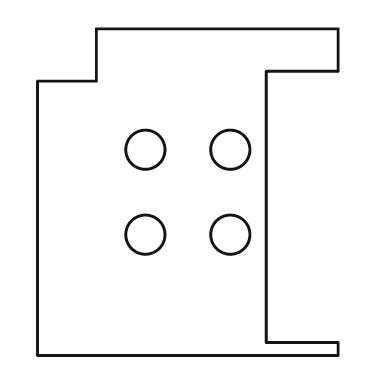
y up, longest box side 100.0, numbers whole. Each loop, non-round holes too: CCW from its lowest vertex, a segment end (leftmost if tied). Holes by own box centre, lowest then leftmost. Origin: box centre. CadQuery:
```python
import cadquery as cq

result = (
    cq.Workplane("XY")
    .moveTo(-46.0, -50.0)
    .lineTo(46.0, -50.0)
    .lineTo(46.0, -46.0)
    .lineTo(24.0, -46.0)
    .lineTo(24.0, 37.0)
    .lineTo(46.0, 37.0)
    .lineTo(46.0, 50.0)
    .lineTo(-28.0, 50.0)
    .lineTo(-28.0, 34.0)
    .lineTo(-46.0, 34.0)
    .close()
    .moveTo(-13.0, -13.0)
    .circle(6.0)
    .moveTo(13.0, -13.0)
    .circle(6.0)
    .moveTo(-13.0, 13.0)
    .circle(6.0)
    .moveTo(13.0, 13.0)
    .circle(6.0)
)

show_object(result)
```